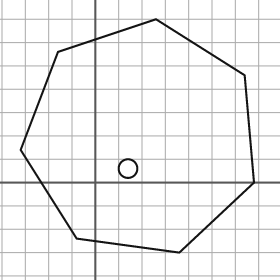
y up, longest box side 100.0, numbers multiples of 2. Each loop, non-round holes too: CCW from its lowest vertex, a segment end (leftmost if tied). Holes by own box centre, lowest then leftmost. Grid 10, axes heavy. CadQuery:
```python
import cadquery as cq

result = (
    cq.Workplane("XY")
    .moveTo(36.0, -30.0)
    .lineTo(68.0, 0.0)
    .lineTo(64.0, 46.0)
    .lineTo(26.0, 70.0)
    .lineTo(-16.0, 56.0)
    .lineTo(-32.0, 14.0)
    .lineTo(-8.0, -24.0)
    .close()
    .moveTo(14.0, 6.0)
    .circle(4.0)
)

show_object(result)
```